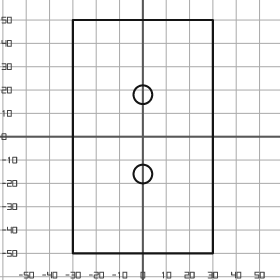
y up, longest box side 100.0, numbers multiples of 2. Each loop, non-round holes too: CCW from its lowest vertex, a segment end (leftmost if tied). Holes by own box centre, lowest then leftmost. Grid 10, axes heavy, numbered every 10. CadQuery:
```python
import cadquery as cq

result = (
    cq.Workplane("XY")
    .moveTo(-30.0, -50.0)
    .lineTo(30.0, -50.0)
    .lineTo(30.0, 50.0)
    .lineTo(-30.0, 50.0)
    .close()
    .moveTo(0.0, -16.0)
    .circle(4.0)
    .moveTo(0.0, 18.0)
    .circle(4.0)
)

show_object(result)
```